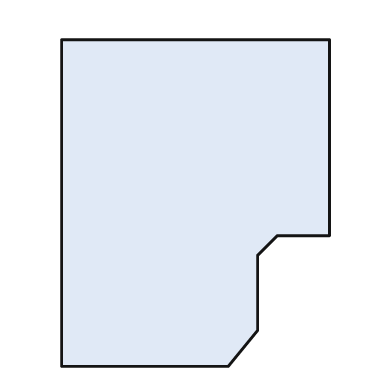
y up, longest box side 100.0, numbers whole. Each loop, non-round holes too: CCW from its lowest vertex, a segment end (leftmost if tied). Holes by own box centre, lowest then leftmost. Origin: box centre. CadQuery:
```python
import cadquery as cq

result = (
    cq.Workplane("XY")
    .moveTo(-41.0, -50.0)
    .lineTo(10.0, -50.0)
    .lineTo(19.0, -39.0)
    .lineTo(19.0, -16.0)
    .lineTo(25.0, -10.0)
    .lineTo(41.0, -10.0)
    .lineTo(41.0, 50.0)
    .lineTo(-41.0, 50.0)
    .close()
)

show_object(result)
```